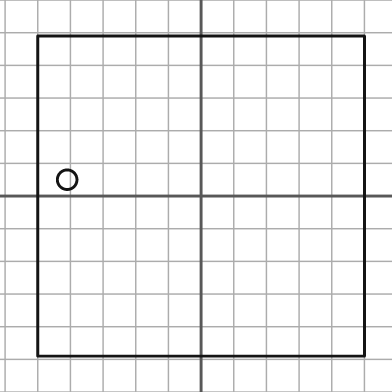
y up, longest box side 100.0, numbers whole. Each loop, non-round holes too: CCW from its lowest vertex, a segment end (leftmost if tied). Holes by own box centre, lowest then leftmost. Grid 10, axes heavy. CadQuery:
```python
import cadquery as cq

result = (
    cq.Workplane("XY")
    .moveTo(-50.0, -49.0)
    .lineTo(50.0, -49.0)
    .lineTo(50.0, 49.0)
    .lineTo(-50.0, 49.0)
    .close()
    .moveTo(-41.0, 5.0)
    .circle(3.0)
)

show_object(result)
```